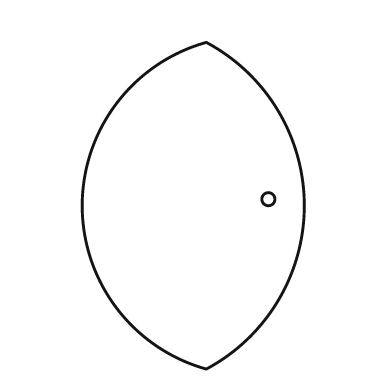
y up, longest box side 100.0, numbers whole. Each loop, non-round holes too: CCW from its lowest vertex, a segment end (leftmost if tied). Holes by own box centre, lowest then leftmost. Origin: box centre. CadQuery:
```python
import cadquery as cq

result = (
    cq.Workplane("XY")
    .moveTo(4.0, -50.0)
    .threePointArc((34.0, 0.0), (4.0, 50.0))
    .threePointArc((-34.0, 0.0), (4.0, -50.0))
    .close()
    .moveTo(23.0, 2.0)
    .circle(2.0)
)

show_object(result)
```